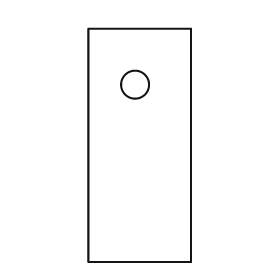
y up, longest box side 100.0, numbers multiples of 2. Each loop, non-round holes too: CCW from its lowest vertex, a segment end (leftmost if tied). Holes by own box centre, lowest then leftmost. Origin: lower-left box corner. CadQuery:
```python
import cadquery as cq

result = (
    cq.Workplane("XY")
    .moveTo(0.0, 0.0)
    .lineTo(44.0, 0.0)
    .lineTo(44.0, 100.0)
    .lineTo(0.0, 100.0)
    .close()
    .moveTo(20.0, 76.0)
    .circle(6.0)
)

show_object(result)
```